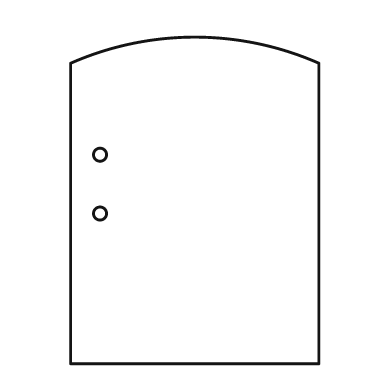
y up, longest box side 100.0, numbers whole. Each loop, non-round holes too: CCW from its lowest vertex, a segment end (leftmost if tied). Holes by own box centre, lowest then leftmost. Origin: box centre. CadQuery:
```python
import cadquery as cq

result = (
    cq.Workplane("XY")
    .moveTo(-38.0, -50.0)
    .lineTo(38.0, -50.0)
    .lineTo(38.0, 42.0)
    .threePointArc((0.0, 50.0), (-38.0, 42.0))
    .close()
    .moveTo(-29.0, -4.0)
    .circle(2.0)
    .moveTo(-29.0, 14.0)
    .circle(2.0)
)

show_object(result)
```